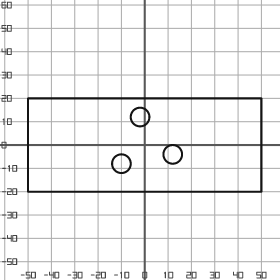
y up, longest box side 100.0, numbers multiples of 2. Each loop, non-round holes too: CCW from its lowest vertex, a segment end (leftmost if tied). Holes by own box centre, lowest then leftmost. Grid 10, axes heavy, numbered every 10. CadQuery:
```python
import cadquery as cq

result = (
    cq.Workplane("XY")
    .moveTo(-50.0, -20.0)
    .lineTo(50.0, -20.0)
    .lineTo(50.0, 20.0)
    .lineTo(-50.0, 20.0)
    .close()
    .moveTo(-10.0, -8.0)
    .circle(4.0)
    .moveTo(12.0, -4.0)
    .circle(4.0)
    .moveTo(-2.0, 12.0)
    .circle(4.0)
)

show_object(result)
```